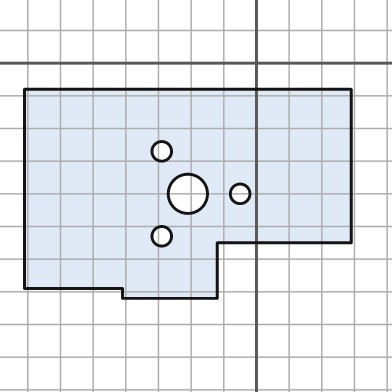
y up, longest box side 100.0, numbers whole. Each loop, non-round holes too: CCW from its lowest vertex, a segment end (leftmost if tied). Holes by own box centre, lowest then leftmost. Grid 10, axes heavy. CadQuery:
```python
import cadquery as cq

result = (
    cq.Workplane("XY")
    .moveTo(-41.0, -72.0)
    .lineTo(-12.0, -72.0)
    .lineTo(-12.0, -55.0)
    .lineTo(29.0, -55.0)
    .lineTo(29.0, -8.0)
    .lineTo(-71.0, -8.0)
    .lineTo(-71.0, -69.0)
    .lineTo(-41.0, -69.0)
    .close()
    .moveTo(-29.0, -53.0)
    .circle(3.0)
    .moveTo(-21.0, -40.0)
    .circle(6.0)
    .moveTo(-5.0, -40.0)
    .circle(3.0)
    .moveTo(-29.0, -27.0)
    .circle(3.0)
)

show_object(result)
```